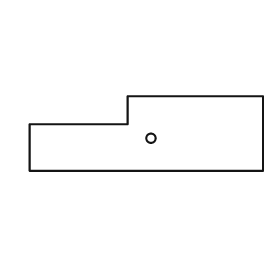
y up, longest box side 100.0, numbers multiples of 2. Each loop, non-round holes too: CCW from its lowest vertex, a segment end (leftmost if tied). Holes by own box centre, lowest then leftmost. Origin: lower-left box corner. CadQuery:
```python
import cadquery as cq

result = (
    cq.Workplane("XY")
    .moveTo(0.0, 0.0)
    .lineTo(100.0, 0.0)
    .lineTo(100.0, 32.0)
    .lineTo(42.0, 32.0)
    .lineTo(42.0, 20.0)
    .lineTo(0.0, 20.0)
    .close()
    .moveTo(52.0, 14.0)
    .circle(2.0)
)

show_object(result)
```